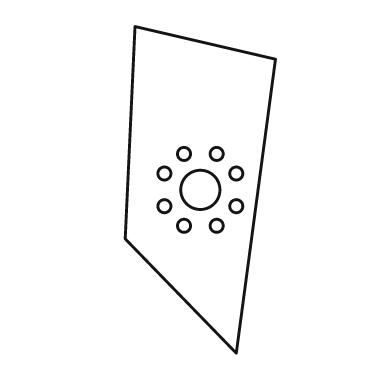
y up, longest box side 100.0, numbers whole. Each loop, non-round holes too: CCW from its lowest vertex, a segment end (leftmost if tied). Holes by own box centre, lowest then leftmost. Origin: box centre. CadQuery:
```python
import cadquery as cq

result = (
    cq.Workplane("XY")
    .moveTo(11.0, -50.0)
    .lineTo(23.0, 40.0)
    .lineTo(-20.0, 50.0)
    .lineTo(-23.0, -15.0)
    .close()
    .moveTo(-5.0, -11.0)
    .circle(2.0)
    .moveTo(5.0, -11.0)
    .circle(2.0)
    .moveTo(-11.0, -5.0)
    .circle(2.0)
    .moveTo(11.0, -5.0)
    .circle(2.0)
    .moveTo(0.0, 0.0)
    .circle(6.0)
    .moveTo(-11.0, 5.0)
    .circle(2.0)
    .moveTo(11.0, 5.0)
    .circle(2.0)
    .moveTo(-5.0, 11.0)
    .circle(2.0)
    .moveTo(5.0, 11.0)
    .circle(2.0)
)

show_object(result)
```